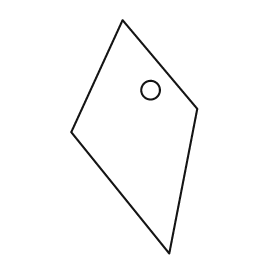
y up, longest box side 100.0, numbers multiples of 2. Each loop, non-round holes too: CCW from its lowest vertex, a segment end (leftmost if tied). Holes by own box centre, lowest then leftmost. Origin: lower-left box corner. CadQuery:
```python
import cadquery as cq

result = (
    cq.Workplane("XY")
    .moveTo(42.0, 0.0)
    .lineTo(54.0, 62.0)
    .lineTo(22.0, 100.0)
    .lineTo(0.0, 52.0)
    .close()
    .moveTo(34.0, 70.0)
    .circle(4.0)
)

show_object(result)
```